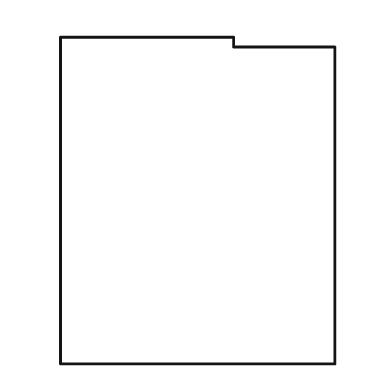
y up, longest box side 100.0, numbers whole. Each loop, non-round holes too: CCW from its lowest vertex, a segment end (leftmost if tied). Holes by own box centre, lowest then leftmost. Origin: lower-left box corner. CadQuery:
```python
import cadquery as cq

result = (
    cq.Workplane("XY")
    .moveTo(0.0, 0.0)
    .lineTo(84.0, 0.0)
    .lineTo(84.0, 97.0)
    .lineTo(53.0, 97.0)
    .lineTo(53.0, 100.0)
    .lineTo(0.0, 100.0)
    .close()
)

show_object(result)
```